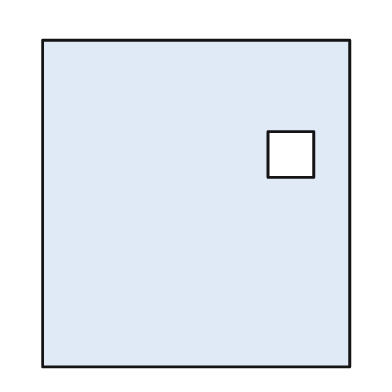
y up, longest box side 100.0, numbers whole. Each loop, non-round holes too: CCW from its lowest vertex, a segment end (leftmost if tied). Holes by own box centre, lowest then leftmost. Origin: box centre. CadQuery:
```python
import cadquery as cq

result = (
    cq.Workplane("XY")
    .moveTo(-47.0, -50.0)
    .lineTo(47.0, -50.0)
    .lineTo(47.0, 50.0)
    .lineTo(-47.0, 50.0)
    .close()
    .moveTo(22.0, 8.0)
    .lineTo(36.0, 8.0)
    .lineTo(36.0, 22.0)
    .lineTo(22.0, 22.0)
    .close()
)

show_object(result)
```